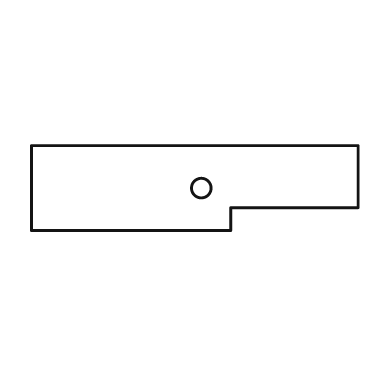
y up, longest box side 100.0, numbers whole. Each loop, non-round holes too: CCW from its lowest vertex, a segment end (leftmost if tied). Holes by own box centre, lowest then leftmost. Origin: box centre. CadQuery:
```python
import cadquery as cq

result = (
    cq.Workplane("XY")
    .moveTo(-50.0, -13.0)
    .lineTo(11.0, -13.0)
    .lineTo(11.0, -6.0)
    .lineTo(50.0, -6.0)
    .lineTo(50.0, 13.0)
    .lineTo(-50.0, 13.0)
    .close()
    .moveTo(2.0, 0.0)
    .circle(3.0)
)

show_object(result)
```